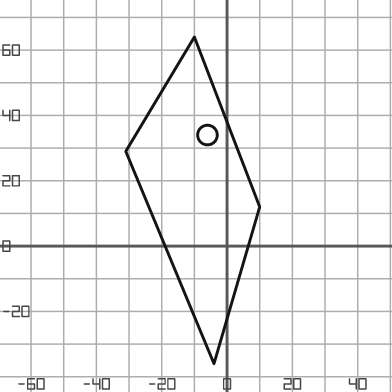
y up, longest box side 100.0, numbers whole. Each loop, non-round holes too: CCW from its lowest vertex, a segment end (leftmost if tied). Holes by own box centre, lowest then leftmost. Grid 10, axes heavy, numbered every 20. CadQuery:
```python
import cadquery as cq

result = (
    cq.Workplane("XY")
    .moveTo(-4.0, -36.0)
    .lineTo(10.0, 12.0)
    .lineTo(-10.0, 64.0)
    .lineTo(-31.0, 29.0)
    .close()
    .moveTo(-6.0, 34.0)
    .circle(3.0)
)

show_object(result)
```